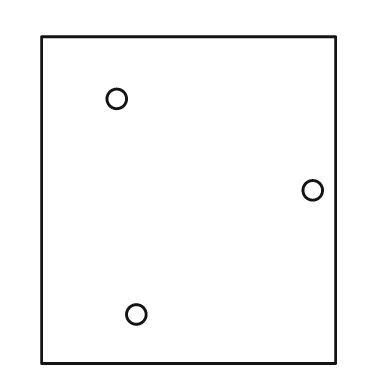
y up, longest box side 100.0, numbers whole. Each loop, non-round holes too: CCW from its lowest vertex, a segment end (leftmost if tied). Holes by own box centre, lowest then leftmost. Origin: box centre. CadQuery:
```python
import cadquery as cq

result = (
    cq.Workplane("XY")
    .moveTo(-45.0, -50.0)
    .lineTo(45.0, -50.0)
    .lineTo(45.0, 50.0)
    .lineTo(-45.0, 50.0)
    .close()
    .moveTo(-16.0, -35.0)
    .circle(3.0)
    .moveTo(38.0, 3.0)
    .circle(3.0)
    .moveTo(-22.0, 31.0)
    .circle(3.0)
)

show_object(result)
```